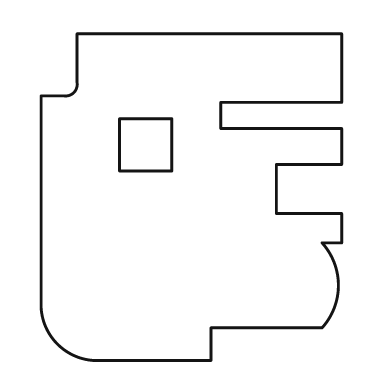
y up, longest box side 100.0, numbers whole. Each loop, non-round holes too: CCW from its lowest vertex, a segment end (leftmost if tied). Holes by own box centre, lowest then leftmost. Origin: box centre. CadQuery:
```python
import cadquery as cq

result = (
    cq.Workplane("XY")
    .moveTo(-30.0, -50.0)
    .lineTo(6.0, -50.0)
    .lineTo(6.0, -40.0)
    .lineTo(40.0, -40.0)
    .threePointArc((45.0, -27.0), (40.0, -14.0))
    .lineTo(46.0, -14.0)
    .lineTo(46.0, -5.0)
    .lineTo(26.0, -5.0)
    .lineTo(26.0, 10.0)
    .lineTo(46.0, 10.0)
    .lineTo(46.0, 21.0)
    .lineTo(9.0, 21.0)
    .lineTo(9.0, 29.0)
    .lineTo(46.0, 29.0)
    .lineTo(46.0, 50.0)
    .lineTo(-35.0, 50.0)
    .lineTo(-35.0, 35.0)
    .threePointArc((-36.0, 32.0), (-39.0, 31.0))
    .lineTo(-46.0, 31.0)
    .lineTo(-46.0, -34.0)
    .threePointArc((-41.0, -45.0), (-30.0, -50.0))
    .close()
    .moveTo(-22.0, 8.0)
    .lineTo(-6.0, 8.0)
    .lineTo(-6.0, 24.0)
    .lineTo(-22.0, 24.0)
    .close()
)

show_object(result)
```